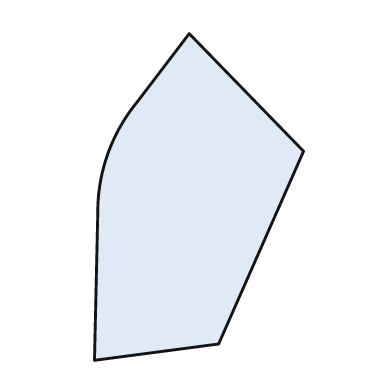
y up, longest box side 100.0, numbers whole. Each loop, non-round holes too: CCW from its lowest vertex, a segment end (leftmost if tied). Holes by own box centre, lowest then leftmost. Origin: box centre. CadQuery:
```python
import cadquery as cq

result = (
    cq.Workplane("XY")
    .moveTo(-32.0, -50.0)
    .lineTo(6.0, -45.0)
    .lineTo(32.0, 14.0)
    .lineTo(-3.0, 50.0)
    .lineTo(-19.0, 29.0)
    .threePointArc((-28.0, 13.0), (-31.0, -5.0))
    .close()
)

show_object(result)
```